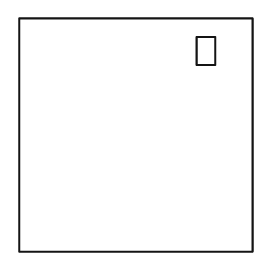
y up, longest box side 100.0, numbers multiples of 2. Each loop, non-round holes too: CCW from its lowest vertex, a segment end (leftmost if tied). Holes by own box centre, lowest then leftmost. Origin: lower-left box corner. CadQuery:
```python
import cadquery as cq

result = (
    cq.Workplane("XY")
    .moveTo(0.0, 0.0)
    .lineTo(100.0, 0.0)
    .lineTo(100.0, 100.0)
    .lineTo(0.0, 100.0)
    .close()
    .moveTo(76.0, 80.0)
    .lineTo(84.0, 80.0)
    .lineTo(84.0, 92.0)
    .lineTo(76.0, 92.0)
    .close()
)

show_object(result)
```